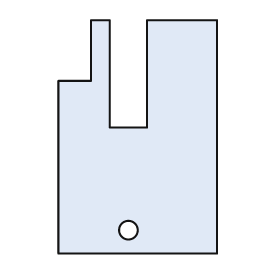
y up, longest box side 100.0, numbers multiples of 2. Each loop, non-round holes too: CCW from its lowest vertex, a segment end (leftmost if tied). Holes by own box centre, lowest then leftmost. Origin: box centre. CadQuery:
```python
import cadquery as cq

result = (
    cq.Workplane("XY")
    .moveTo(-34.0, -50.0)
    .lineTo(34.0, -50.0)
    .lineTo(34.0, 50.0)
    .lineTo(4.0, 50.0)
    .lineTo(4.0, 4.0)
    .lineTo(-12.0, 4.0)
    .lineTo(-12.0, 50.0)
    .lineTo(-20.0, 50.0)
    .lineTo(-20.0, 24.0)
    .lineTo(-34.0, 24.0)
    .close()
    .moveTo(-4.0, -40.0)
    .circle(4.0)
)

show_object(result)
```